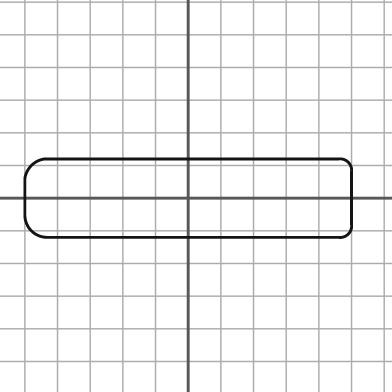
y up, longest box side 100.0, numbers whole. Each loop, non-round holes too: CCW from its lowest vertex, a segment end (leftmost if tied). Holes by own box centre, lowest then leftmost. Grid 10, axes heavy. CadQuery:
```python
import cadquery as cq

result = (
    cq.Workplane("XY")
    .moveTo(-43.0, -12.0)
    .lineTo(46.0, -12.0)
    .threePointArc((49.0, -11.0), (50.0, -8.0))
    .lineTo(50.0, 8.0)
    .threePointArc((49.0, 11.0), (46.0, 12.0))
    .lineTo(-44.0, 12.0)
    .threePointArc((-48.0, 10.0), (-50.0, 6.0))
    .lineTo(-50.0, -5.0)
    .threePointArc((-48.0, -10.0), (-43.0, -12.0))
    .close()
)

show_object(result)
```